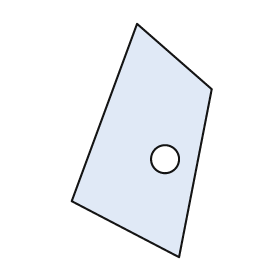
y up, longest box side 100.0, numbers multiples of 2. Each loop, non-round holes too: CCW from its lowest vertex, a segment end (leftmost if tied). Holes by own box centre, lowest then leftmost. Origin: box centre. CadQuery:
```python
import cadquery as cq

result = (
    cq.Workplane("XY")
    .moveTo(16.0, -50.0)
    .lineTo(30.0, 22.0)
    .lineTo(-2.0, 50.0)
    .lineTo(-30.0, -26.0)
    .close()
    .moveTo(10.0, -8.0)
    .circle(6.0)
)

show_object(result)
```